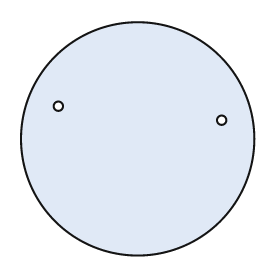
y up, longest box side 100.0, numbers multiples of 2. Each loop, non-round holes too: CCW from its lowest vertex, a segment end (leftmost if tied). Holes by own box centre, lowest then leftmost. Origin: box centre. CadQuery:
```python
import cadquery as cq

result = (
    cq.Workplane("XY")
    .moveTo(0.0, 0.0)
    .circle(50.0)
    .moveTo(36.0, 8.0)
    .circle(2.0)
    .moveTo(-34.0, 14.0)
    .circle(2.0)
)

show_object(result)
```